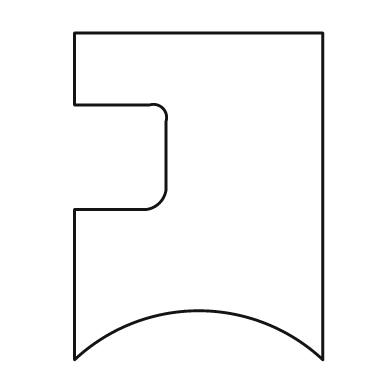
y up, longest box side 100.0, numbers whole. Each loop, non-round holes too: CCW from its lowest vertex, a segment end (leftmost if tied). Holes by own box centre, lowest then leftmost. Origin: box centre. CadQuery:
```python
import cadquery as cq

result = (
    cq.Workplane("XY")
    .moveTo(-38.0, -50.0)
    .threePointArc((0.0, -35.0), (38.0, -50.0))
    .lineTo(38.0, 50.0)
    .lineTo(-38.0, 50.0)
    .lineTo(-38.0, 28.0)
    .lineTo(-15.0, 28.0)
    .threePointArc((-11.0, 27.0), (-10.0, 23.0))
    .lineTo(-10.0, 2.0)
    .threePointArc((-12.0, -2.0), (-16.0, -4.0))
    .lineTo(-38.0, -4.0)
    .close()
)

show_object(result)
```